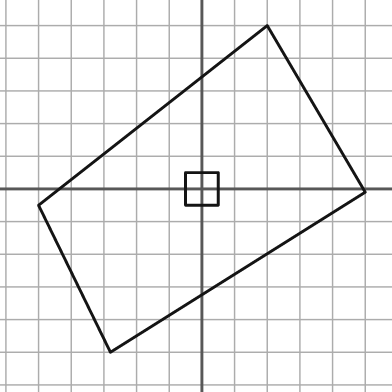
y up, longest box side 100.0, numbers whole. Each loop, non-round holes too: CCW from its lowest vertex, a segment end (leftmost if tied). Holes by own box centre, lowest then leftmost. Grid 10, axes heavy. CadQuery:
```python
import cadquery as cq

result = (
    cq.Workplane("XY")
    .moveTo(-28.0, -50.0)
    .lineTo(50.0, -1.0)
    .lineTo(20.0, 50.0)
    .lineTo(-50.0, -5.0)
    .close()
    .moveTo(-5.0, -5.0)
    .lineTo(5.0, -5.0)
    .lineTo(5.0, 5.0)
    .lineTo(-5.0, 5.0)
    .close()
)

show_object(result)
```